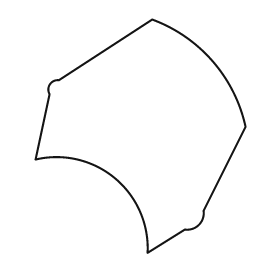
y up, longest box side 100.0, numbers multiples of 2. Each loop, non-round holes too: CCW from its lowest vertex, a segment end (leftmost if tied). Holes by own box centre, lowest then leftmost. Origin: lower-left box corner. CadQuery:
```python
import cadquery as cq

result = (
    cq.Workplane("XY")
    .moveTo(48.0, 0.0)
    .lineTo(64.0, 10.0)
    .threePointArc((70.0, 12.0), (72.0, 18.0))
    .lineTo(90.0, 54.0)
    .threePointArc((76.0, 82.0), (50.0, 100.0))
    .lineTo(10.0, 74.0)
    .threePointArc((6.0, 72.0), (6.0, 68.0))
    .lineTo(0.0, 40.0)
    .threePointArc((34.0, 32.0), (48.0, 0.0))
    .close()
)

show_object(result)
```